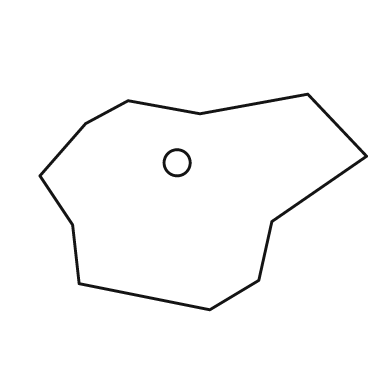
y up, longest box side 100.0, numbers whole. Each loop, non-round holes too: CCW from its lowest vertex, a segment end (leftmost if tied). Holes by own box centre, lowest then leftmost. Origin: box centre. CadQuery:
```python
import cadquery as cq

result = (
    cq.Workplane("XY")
    .moveTo(2.0, -33.0)
    .lineTo(17.0, -24.0)
    .lineTo(21.0, -6.0)
    .lineTo(50.0, 14.0)
    .lineTo(32.0, 33.0)
    .lineTo(-1.0, 27.0)
    .lineTo(-23.0, 31.0)
    .lineTo(-36.0, 24.0)
    .lineTo(-50.0, 8.0)
    .lineTo(-40.0, -7.0)
    .lineTo(-38.0, -25.0)
    .close()
    .moveTo(-8.0, 12.0)
    .circle(4.0)
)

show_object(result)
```